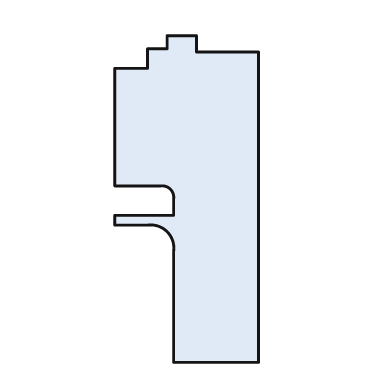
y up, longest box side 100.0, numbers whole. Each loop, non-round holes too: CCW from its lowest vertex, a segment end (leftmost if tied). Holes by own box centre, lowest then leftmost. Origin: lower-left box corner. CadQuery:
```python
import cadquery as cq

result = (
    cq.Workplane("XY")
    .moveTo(18.0, 0.0)
    .lineTo(44.0, 0.0)
    .lineTo(44.0, 95.0)
    .lineTo(25.0, 95.0)
    .lineTo(25.0, 100.0)
    .lineTo(16.0, 100.0)
    .lineTo(16.0, 96.0)
    .lineTo(10.0, 96.0)
    .lineTo(10.0, 90.0)
    .lineTo(0.0, 90.0)
    .lineTo(0.0, 54.0)
    .lineTo(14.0, 54.0)
    .threePointArc((17.0, 53.0), (18.0, 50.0))
    .lineTo(18.0, 45.0)
    .lineTo(0.0, 45.0)
    .lineTo(0.0, 42.0)
    .lineTo(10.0, 42.0)
    .threePointArc((16.0, 40.0), (18.0, 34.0))
    .close()
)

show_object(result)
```